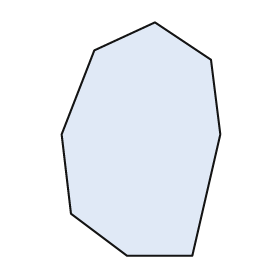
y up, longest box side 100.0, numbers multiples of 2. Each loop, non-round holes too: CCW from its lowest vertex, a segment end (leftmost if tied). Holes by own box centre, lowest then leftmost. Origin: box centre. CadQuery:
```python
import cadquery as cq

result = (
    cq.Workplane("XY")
    .moveTo(-6.0, -50.0)
    .lineTo(22.0, -50.0)
    .lineTo(34.0, 2.0)
    .lineTo(30.0, 34.0)
    .lineTo(6.0, 50.0)
    .lineTo(-20.0, 38.0)
    .lineTo(-34.0, 2.0)
    .lineTo(-30.0, -32.0)
    .close()
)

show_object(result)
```